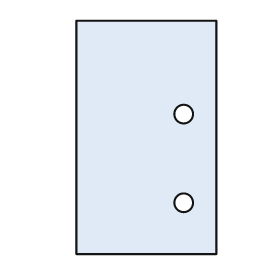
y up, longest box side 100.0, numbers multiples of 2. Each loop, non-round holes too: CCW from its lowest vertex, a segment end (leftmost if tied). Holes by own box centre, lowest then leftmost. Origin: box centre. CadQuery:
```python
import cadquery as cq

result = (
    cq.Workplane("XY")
    .moveTo(-30.0, -50.0)
    .lineTo(30.0, -50.0)
    .lineTo(30.0, 50.0)
    .lineTo(-30.0, 50.0)
    .close()
    .moveTo(16.0, -28.0)
    .circle(4.0)
    .moveTo(16.0, 10.0)
    .circle(4.0)
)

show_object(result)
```